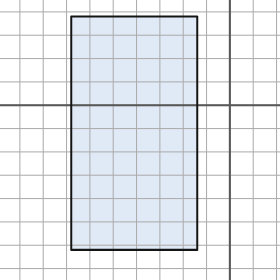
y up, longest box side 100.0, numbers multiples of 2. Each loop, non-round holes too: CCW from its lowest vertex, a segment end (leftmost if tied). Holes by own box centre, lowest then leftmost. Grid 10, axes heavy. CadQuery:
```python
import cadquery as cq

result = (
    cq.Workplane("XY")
    .moveTo(-68.0, -62.0)
    .lineTo(-14.0, -62.0)
    .lineTo(-14.0, 38.0)
    .lineTo(-68.0, 38.0)
    .close()
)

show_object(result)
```